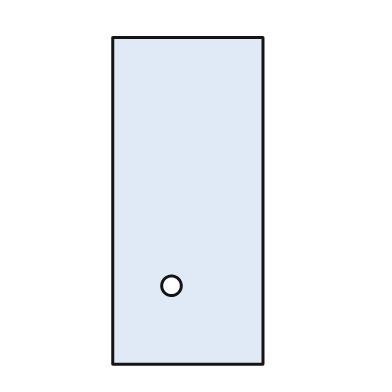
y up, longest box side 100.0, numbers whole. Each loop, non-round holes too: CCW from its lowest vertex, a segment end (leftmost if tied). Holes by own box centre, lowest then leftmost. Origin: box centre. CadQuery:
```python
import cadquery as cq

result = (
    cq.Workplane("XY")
    .moveTo(-23.0, -50.0)
    .lineTo(23.0, -50.0)
    .lineTo(23.0, 50.0)
    .lineTo(-23.0, 50.0)
    .close()
    .moveTo(-5.0, -26.0)
    .circle(3.0)
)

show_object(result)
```